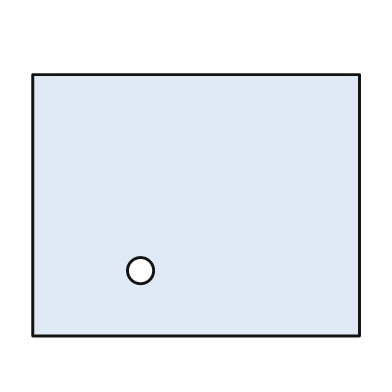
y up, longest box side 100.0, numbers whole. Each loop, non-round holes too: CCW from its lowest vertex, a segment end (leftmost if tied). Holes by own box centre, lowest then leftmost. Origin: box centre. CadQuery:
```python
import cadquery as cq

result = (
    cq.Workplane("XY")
    .moveTo(-50.0, -40.0)
    .lineTo(50.0, -40.0)
    .lineTo(50.0, 40.0)
    .lineTo(-50.0, 40.0)
    .close()
    .moveTo(-17.0, -20.0)
    .circle(4.0)
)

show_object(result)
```